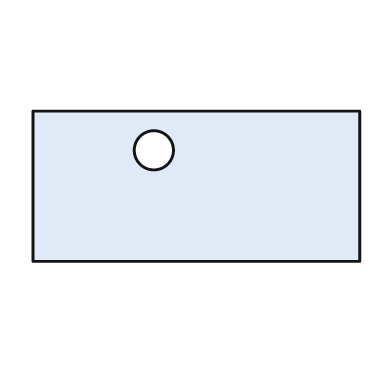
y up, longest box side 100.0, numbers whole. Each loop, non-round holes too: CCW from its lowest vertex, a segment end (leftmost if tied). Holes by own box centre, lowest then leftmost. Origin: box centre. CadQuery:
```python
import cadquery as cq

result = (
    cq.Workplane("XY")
    .moveTo(-50.0, -23.0)
    .lineTo(50.0, -23.0)
    .lineTo(50.0, 23.0)
    .lineTo(-50.0, 23.0)
    .close()
    .moveTo(-13.0, 11.0)
    .circle(6.0)
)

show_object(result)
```